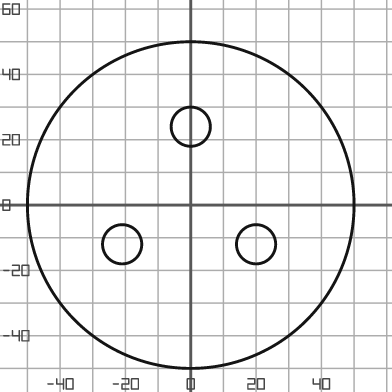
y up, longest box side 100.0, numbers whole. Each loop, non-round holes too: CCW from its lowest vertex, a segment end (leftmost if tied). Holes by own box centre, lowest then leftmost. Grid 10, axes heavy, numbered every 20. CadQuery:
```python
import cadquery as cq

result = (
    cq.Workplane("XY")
    .moveTo(0.0, 0.0)
    .circle(50.0)
    .moveTo(-21.0, -12.0)
    .circle(6.0)
    .moveTo(20.0, -12.0)
    .circle(6.0)
    .moveTo(0.0, 24.0)
    .circle(6.0)
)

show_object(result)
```